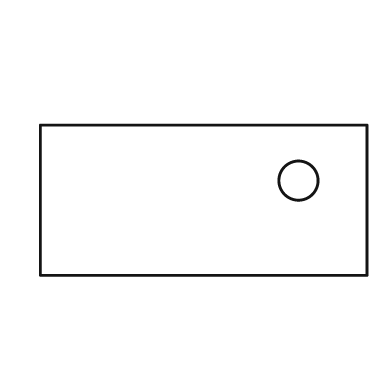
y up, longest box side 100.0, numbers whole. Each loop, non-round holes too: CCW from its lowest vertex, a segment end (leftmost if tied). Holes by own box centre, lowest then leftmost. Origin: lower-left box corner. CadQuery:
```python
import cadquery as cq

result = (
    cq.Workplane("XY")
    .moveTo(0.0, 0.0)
    .lineTo(100.0, 0.0)
    .lineTo(100.0, 46.0)
    .lineTo(0.0, 46.0)
    .close()
    .moveTo(79.0, 29.0)
    .circle(6.0)
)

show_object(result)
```